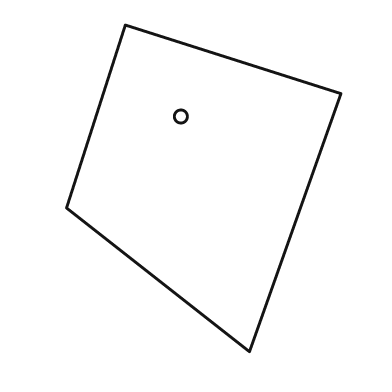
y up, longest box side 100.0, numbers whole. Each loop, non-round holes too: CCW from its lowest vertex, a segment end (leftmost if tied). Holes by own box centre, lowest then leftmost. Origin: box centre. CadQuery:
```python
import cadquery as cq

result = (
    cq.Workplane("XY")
    .moveTo(14.0, -50.0)
    .lineTo(42.0, 29.0)
    .lineTo(-24.0, 50.0)
    .lineTo(-42.0, -6.0)
    .close()
    .moveTo(-7.0, 22.0)
    .circle(2.0)
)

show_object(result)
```